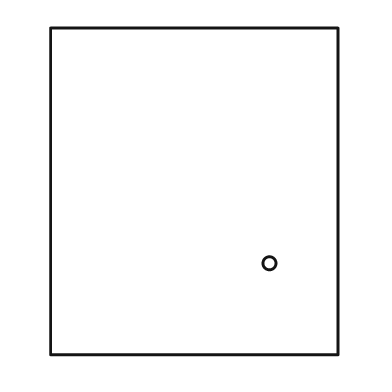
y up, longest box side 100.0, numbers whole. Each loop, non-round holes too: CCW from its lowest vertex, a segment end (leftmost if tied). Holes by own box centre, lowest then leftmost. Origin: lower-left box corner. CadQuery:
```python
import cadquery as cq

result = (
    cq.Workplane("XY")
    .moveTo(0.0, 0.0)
    .lineTo(88.0, 0.0)
    .lineTo(88.0, 100.0)
    .lineTo(0.0, 100.0)
    .close()
    .moveTo(67.0, 28.0)
    .circle(2.0)
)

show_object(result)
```